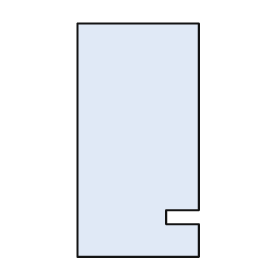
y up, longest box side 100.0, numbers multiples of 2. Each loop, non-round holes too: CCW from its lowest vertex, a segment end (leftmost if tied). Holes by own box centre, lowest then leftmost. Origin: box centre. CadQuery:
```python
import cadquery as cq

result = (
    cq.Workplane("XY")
    .moveTo(-26.0, -50.0)
    .lineTo(26.0, -50.0)
    .lineTo(26.0, -36.0)
    .lineTo(12.0, -36.0)
    .lineTo(12.0, -30.0)
    .lineTo(26.0, -30.0)
    .lineTo(26.0, 50.0)
    .lineTo(-26.0, 50.0)
    .close()
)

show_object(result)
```